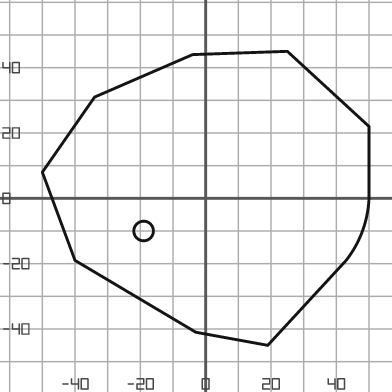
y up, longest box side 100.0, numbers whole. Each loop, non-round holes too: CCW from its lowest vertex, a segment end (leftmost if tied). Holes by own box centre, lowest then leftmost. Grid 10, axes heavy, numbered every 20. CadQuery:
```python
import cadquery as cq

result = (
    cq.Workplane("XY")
    .moveTo(19.0, -45.0)
    .lineTo(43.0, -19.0)
    .threePointArc((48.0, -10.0), (50.0, 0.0))
    .lineTo(50.0, 22.0)
    .lineTo(25.0, 45.0)
    .lineTo(-4.0, 44.0)
    .lineTo(-34.0, 31.0)
    .lineTo(-50.0, 8.0)
    .lineTo(-40.0, -19.0)
    .lineTo(-3.0, -41.0)
    .close()
    .moveTo(-19.0, -10.0)
    .circle(3.0)
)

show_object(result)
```